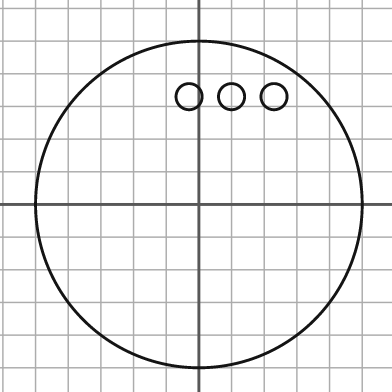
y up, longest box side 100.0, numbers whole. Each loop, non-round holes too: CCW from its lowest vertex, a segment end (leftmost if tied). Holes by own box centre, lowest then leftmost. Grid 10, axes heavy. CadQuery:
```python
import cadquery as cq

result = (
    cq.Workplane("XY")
    .moveTo(0.0, 0.0)
    .circle(50.0)
    .moveTo(-3.0, 33.0)
    .circle(4.0)
    .moveTo(10.0, 33.0)
    .circle(4.0)
    .moveTo(23.0, 33.0)
    .circle(4.0)
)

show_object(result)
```